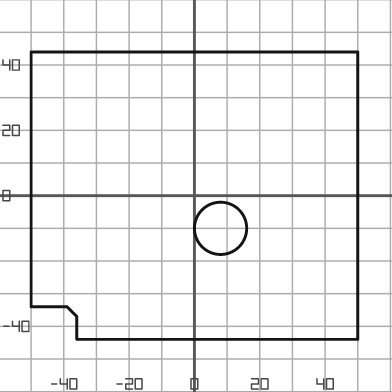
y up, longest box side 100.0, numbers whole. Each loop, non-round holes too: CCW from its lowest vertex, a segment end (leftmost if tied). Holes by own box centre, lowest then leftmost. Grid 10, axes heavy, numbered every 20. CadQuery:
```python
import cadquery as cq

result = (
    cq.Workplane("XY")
    .moveTo(-36.0, -44.0)
    .lineTo(50.0, -44.0)
    .lineTo(50.0, 44.0)
    .lineTo(-50.0, 44.0)
    .lineTo(-50.0, -34.0)
    .lineTo(-39.0, -34.0)
    .lineTo(-36.0, -37.0)
    .close()
    .moveTo(8.0, -10.0)
    .circle(8.0)
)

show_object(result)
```